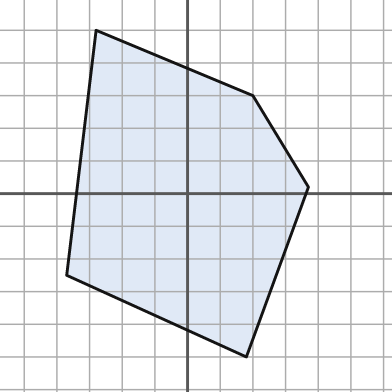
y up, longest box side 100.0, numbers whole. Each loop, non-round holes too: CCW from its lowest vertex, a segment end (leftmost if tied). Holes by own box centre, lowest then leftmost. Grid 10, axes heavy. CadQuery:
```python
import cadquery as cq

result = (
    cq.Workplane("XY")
    .moveTo(18.0, -50.0)
    .lineTo(37.0, 2.0)
    .lineTo(20.0, 30.0)
    .lineTo(-28.0, 50.0)
    .lineTo(-37.0, -25.0)
    .close()
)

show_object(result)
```